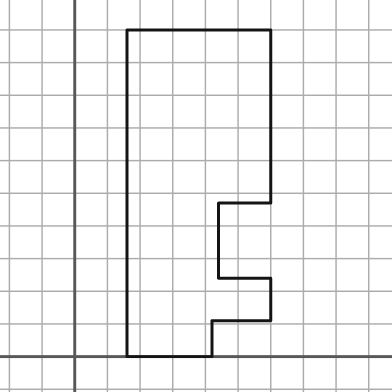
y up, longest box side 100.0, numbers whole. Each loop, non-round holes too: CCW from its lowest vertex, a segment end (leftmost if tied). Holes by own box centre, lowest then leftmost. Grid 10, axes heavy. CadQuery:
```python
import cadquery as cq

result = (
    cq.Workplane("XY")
    .moveTo(16.0, 0.0)
    .lineTo(42.0, 0.0)
    .lineTo(42.0, 11.0)
    .lineTo(60.0, 11.0)
    .lineTo(60.0, 24.0)
    .lineTo(44.0, 24.0)
    .lineTo(44.0, 47.0)
    .lineTo(60.0, 47.0)
    .lineTo(60.0, 100.0)
    .lineTo(16.0, 100.0)
    .close()
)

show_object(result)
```